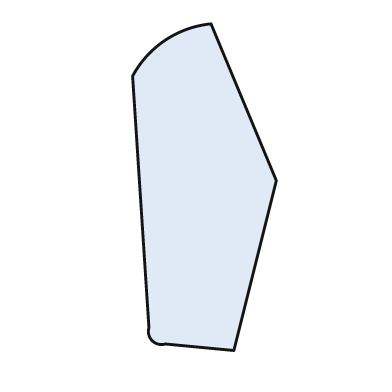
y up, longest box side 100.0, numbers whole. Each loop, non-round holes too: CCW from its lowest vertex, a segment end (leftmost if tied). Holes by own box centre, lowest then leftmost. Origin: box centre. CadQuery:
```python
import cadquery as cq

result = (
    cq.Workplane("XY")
    .moveTo(9.0, -50.0)
    .lineTo(22.0, 2.0)
    .lineTo(2.0, 50.0)
    .threePointArc((-12.0, 45.0), (-22.0, 34.0))
    .lineTo(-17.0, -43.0)
    .threePointArc((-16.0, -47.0), (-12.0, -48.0))
    .close()
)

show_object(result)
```